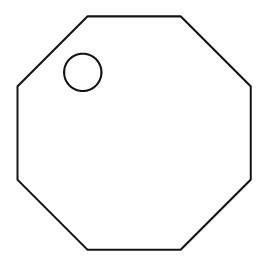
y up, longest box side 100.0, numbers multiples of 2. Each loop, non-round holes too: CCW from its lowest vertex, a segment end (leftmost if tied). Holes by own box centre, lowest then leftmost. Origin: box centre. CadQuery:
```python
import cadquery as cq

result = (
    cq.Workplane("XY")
    .moveTo(-20.0, -50.0)
    .lineTo(20.0, -50.0)
    .lineTo(50.0, -20.0)
    .lineTo(50.0, 20.0)
    .lineTo(20.0, 50.0)
    .lineTo(-20.0, 50.0)
    .lineTo(-50.0, 20.0)
    .lineTo(-50.0, -20.0)
    .close()
    .moveTo(-22.0, 26.0)
    .circle(8.0)
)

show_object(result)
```